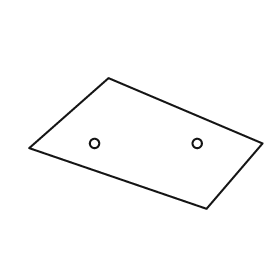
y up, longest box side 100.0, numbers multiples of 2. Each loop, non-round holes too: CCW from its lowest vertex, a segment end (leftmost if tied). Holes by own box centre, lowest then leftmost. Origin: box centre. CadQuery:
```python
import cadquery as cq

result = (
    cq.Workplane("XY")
    .moveTo(26.0, -28.0)
    .lineTo(50.0, 0.0)
    .lineTo(-16.0, 28.0)
    .lineTo(-50.0, -2.0)
    .close()
    .moveTo(-22.0, 0.0)
    .circle(2.0)
    .moveTo(22.0, 0.0)
    .circle(2.0)
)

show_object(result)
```